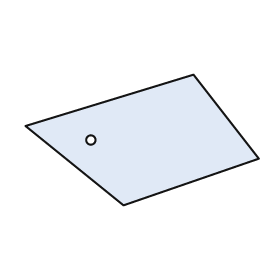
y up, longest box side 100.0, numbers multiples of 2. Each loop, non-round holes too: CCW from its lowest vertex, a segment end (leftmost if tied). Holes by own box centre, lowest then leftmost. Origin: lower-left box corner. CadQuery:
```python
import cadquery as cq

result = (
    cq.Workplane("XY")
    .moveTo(42.0, 0.0)
    .lineTo(100.0, 20.0)
    .lineTo(72.0, 56.0)
    .lineTo(0.0, 34.0)
    .close()
    .moveTo(28.0, 28.0)
    .circle(2.0)
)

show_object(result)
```